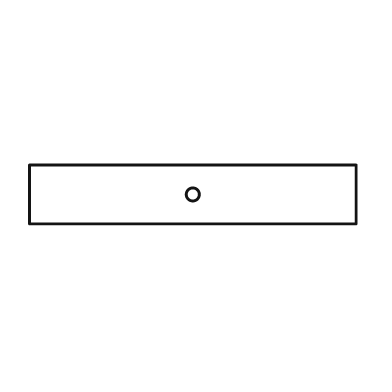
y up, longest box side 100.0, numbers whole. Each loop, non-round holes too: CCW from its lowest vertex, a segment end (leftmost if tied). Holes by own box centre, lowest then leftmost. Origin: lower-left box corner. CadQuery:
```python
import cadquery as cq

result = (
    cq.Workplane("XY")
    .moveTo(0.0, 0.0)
    .lineTo(100.0, 0.0)
    .lineTo(100.0, 18.0)
    .lineTo(0.0, 18.0)
    .close()
    .moveTo(50.0, 9.0)
    .circle(2.0)
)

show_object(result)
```